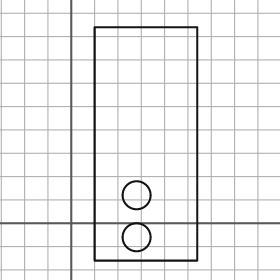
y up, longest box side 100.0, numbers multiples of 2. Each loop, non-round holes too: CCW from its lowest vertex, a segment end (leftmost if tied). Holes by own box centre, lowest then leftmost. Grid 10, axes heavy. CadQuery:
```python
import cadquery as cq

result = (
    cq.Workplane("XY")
    .moveTo(10.0, -16.0)
    .lineTo(54.0, -16.0)
    .lineTo(54.0, 84.0)
    .lineTo(10.0, 84.0)
    .close()
    .moveTo(28.0, -6.0)
    .circle(6.0)
    .moveTo(28.0, 12.0)
    .circle(6.0)
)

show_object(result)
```